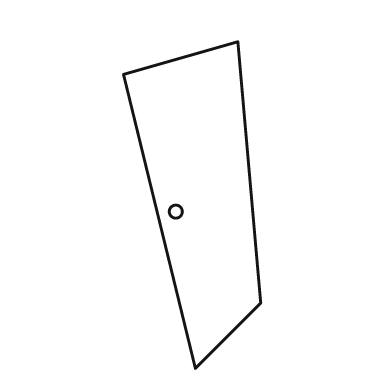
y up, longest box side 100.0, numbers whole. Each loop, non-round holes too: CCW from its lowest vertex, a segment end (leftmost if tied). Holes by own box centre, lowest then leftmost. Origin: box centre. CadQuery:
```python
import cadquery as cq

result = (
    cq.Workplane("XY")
    .moveTo(1.0, -50.0)
    .lineTo(21.0, -30.0)
    .lineTo(14.0, 50.0)
    .lineTo(-21.0, 40.0)
    .close()
    .moveTo(-5.0, -2.0)
    .circle(2.0)
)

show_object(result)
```